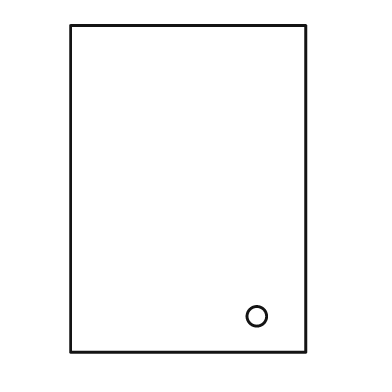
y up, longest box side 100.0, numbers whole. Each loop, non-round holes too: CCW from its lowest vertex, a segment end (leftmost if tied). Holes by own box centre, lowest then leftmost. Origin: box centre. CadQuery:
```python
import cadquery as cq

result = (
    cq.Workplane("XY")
    .moveTo(-36.0, -50.0)
    .lineTo(36.0, -50.0)
    .lineTo(36.0, 50.0)
    .lineTo(-36.0, 50.0)
    .close()
    .moveTo(21.0, -39.0)
    .circle(3.0)
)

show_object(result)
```